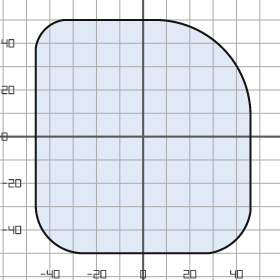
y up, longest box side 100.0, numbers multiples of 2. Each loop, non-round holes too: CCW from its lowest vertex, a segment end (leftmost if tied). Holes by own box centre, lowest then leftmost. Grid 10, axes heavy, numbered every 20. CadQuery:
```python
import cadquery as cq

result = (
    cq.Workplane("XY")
    .moveTo(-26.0, -50.0)
    .lineTo(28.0, -50.0)
    .threePointArc((40.0, -44.0), (46.0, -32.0))
    .lineTo(46.0, 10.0)
    .threePointArc((34.0, 38.0), (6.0, 50.0))
    .lineTo(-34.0, 50.0)
    .threePointArc((-42.0, 46.0), (-46.0, 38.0))
    .lineTo(-46.0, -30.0)
    .threePointArc((-40.0, -44.0), (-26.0, -50.0))
    .close()
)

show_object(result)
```